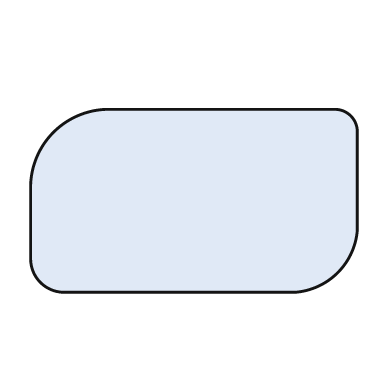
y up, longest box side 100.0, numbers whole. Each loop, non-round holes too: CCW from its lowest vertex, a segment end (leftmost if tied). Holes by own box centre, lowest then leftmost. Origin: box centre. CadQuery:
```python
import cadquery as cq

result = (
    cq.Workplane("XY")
    .moveTo(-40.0, -28.0)
    .lineTo(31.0, -28.0)
    .threePointArc((44.0, -22.0), (50.0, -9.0))
    .lineTo(50.0, 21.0)
    .threePointArc((48.0, 26.0), (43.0, 28.0))
    .lineTo(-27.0, 28.0)
    .threePointArc((-43.0, 21.0), (-50.0, 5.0))
    .lineTo(-50.0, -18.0)
    .threePointArc((-47.0, -25.0), (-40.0, -28.0))
    .close()
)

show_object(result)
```